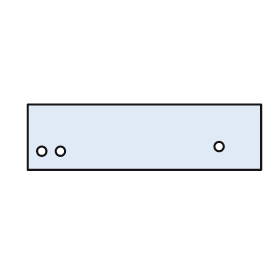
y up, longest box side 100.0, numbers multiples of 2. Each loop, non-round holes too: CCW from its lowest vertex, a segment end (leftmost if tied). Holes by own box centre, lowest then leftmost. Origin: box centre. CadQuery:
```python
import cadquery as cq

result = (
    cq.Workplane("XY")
    .moveTo(-50.0, -14.0)
    .lineTo(50.0, -14.0)
    .lineTo(50.0, 14.0)
    .lineTo(-50.0, 14.0)
    .close()
    .moveTo(-44.0, -6.0)
    .circle(2.0)
    .moveTo(-36.0, -6.0)
    .circle(2.0)
    .moveTo(32.0, -4.0)
    .circle(2.0)
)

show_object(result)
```